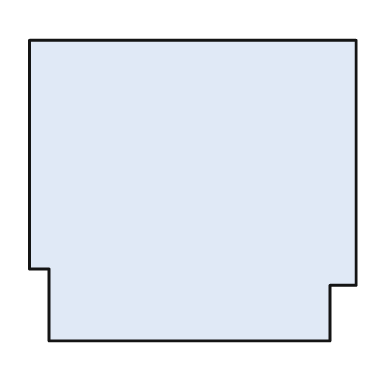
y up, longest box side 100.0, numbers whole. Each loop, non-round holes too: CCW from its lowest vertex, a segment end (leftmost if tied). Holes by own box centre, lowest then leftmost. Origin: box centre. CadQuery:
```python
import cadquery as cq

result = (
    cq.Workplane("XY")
    .moveTo(-44.0, -46.0)
    .lineTo(42.0, -46.0)
    .lineTo(42.0, -29.0)
    .lineTo(50.0, -29.0)
    .lineTo(50.0, 46.0)
    .lineTo(-50.0, 46.0)
    .lineTo(-50.0, -24.0)
    .lineTo(-44.0, -24.0)
    .close()
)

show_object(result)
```